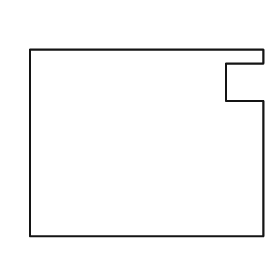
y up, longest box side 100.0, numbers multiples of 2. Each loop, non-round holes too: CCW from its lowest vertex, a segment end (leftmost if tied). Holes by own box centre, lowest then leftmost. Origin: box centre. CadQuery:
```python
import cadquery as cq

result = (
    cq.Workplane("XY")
    .moveTo(-50.0, -40.0)
    .lineTo(50.0, -40.0)
    .lineTo(50.0, 18.0)
    .lineTo(34.0, 18.0)
    .lineTo(34.0, 34.0)
    .lineTo(50.0, 34.0)
    .lineTo(50.0, 40.0)
    .lineTo(-50.0, 40.0)
    .close()
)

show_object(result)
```